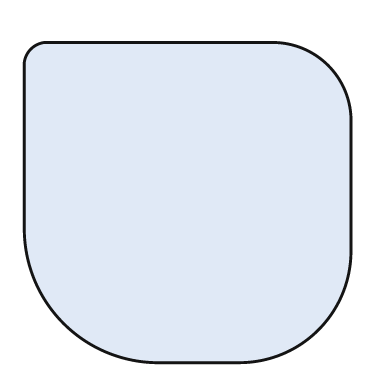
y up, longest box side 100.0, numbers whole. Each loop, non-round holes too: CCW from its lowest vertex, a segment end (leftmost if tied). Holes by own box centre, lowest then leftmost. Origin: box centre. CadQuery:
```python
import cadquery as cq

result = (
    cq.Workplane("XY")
    .moveTo(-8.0, -49.0)
    .lineTo(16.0, -49.0)
    .threePointArc((40.0, -39.0), (50.0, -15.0))
    .lineTo(50.0, 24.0)
    .threePointArc((43.0, 42.0), (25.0, 49.0))
    .lineTo(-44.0, 49.0)
    .threePointArc((-48.0, 47.0), (-50.0, 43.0))
    .lineTo(-50.0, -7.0)
    .threePointArc((-38.0, -37.0), (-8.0, -49.0))
    .close()
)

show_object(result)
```